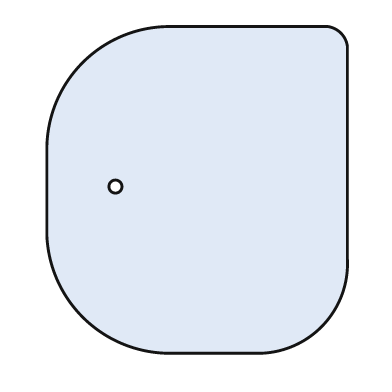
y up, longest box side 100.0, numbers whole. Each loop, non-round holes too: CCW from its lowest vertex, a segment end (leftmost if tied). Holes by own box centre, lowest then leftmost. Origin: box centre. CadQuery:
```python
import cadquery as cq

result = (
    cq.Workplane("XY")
    .moveTo(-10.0, -50.0)
    .lineTo(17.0, -50.0)
    .threePointArc((38.0, -42.0), (46.0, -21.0))
    .lineTo(46.0, 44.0)
    .threePointArc((44.0, 48.0), (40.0, 50.0))
    .lineTo(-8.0, 50.0)
    .threePointArc((-35.0, 39.0), (-46.0, 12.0))
    .lineTo(-46.0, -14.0)
    .threePointArc((-35.0, -39.0), (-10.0, -50.0))
    .close()
    .moveTo(-25.0, 1.0)
    .circle(2.0)
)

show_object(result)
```